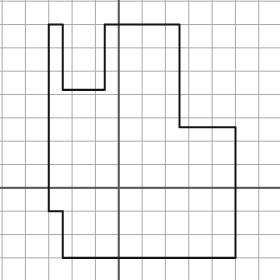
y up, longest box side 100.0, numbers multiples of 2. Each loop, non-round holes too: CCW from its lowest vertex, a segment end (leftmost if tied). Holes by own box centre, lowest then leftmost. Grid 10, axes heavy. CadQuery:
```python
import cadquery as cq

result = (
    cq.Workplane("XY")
    .moveTo(-24.0, -30.0)
    .lineTo(50.0, -30.0)
    .lineTo(50.0, 26.0)
    .lineTo(26.0, 26.0)
    .lineTo(26.0, 70.0)
    .lineTo(-6.0, 70.0)
    .lineTo(-6.0, 42.0)
    .lineTo(-24.0, 42.0)
    .lineTo(-24.0, 70.0)
    .lineTo(-30.0, 70.0)
    .lineTo(-30.0, -10.0)
    .lineTo(-24.0, -10.0)
    .close()
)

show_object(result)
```